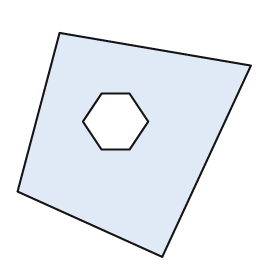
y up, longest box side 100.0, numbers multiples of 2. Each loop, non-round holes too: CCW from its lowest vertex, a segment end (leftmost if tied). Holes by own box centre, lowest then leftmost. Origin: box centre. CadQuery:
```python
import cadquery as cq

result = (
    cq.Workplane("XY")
    .moveTo(12.0, -48.0)
    .lineTo(50.0, 34.0)
    .lineTo(-32.0, 48.0)
    .lineTo(-50.0, -20.0)
    .close()
    .moveTo(-14.0, -2.0)
    .lineTo(-2.0, -2.0)
    .lineTo(6.0, 10.0)
    .lineTo(-2.0, 22.0)
    .lineTo(-14.0, 22.0)
    .lineTo(-22.0, 10.0)
    .close()
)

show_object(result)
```